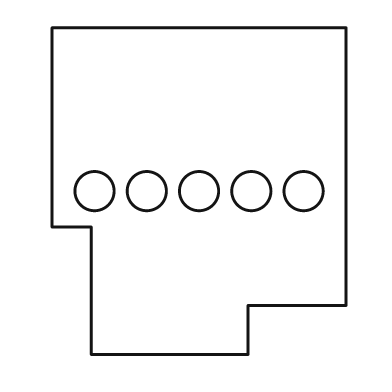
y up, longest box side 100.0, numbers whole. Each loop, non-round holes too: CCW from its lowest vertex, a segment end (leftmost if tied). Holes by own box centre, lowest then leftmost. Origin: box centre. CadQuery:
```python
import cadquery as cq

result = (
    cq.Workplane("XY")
    .moveTo(-33.0, -50.0)
    .lineTo(15.0, -50.0)
    .lineTo(15.0, -35.0)
    .lineTo(45.0, -35.0)
    .lineTo(45.0, 50.0)
    .lineTo(-45.0, 50.0)
    .lineTo(-45.0, -11.0)
    .lineTo(-33.0, -11.0)
    .close()
    .moveTo(-32.0, 0.0)
    .circle(6.0)
    .moveTo(-16.0, 0.0)
    .circle(6.0)
    .moveTo(0.0, 0.0)
    .circle(6.0)
    .moveTo(16.0, 0.0)
    .circle(6.0)
    .moveTo(32.0, 0.0)
    .circle(6.0)
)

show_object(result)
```